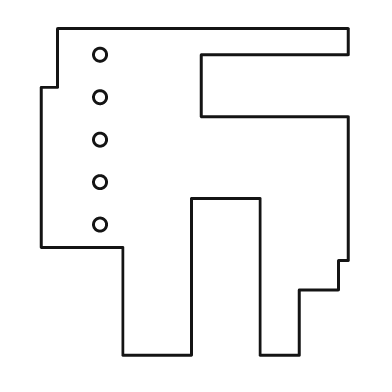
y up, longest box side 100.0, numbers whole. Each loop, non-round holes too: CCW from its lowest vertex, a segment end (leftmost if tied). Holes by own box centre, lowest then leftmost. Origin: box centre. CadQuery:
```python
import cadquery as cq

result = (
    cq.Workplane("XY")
    .moveTo(-22.0, -50.0)
    .lineTo(-1.0, -50.0)
    .lineTo(-1.0, -2.0)
    .lineTo(20.0, -2.0)
    .lineTo(20.0, -50.0)
    .lineTo(32.0, -50.0)
    .lineTo(32.0, -30.0)
    .lineTo(44.0, -30.0)
    .lineTo(44.0, -21.0)
    .lineTo(47.0, -21.0)
    .lineTo(47.0, 23.0)
    .lineTo(2.0, 23.0)
    .lineTo(2.0, 42.0)
    .lineTo(47.0, 42.0)
    .lineTo(47.0, 50.0)
    .lineTo(-42.0, 50.0)
    .lineTo(-42.0, 32.0)
    .lineTo(-47.0, 32.0)
    .lineTo(-47.0, -17.0)
    .lineTo(-22.0, -17.0)
    .close()
    .moveTo(-29.0, -10.0)
    .circle(2.0)
    .moveTo(-29.0, 3.0)
    .circle(2.0)
    .moveTo(-29.0, 16.0)
    .circle(2.0)
    .moveTo(-29.0, 29.0)
    .circle(2.0)
    .moveTo(-29.0, 42.0)
    .circle(2.0)
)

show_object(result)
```